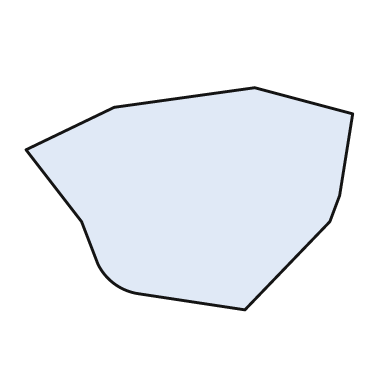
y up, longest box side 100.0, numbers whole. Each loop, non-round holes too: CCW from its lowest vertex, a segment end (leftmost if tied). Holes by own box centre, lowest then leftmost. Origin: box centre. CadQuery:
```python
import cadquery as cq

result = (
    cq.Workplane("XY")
    .moveTo(17.0, -34.0)
    .lineTo(43.0, -7.0)
    .lineTo(46.0, 1.0)
    .lineTo(50.0, 26.0)
    .lineTo(20.0, 34.0)
    .lineTo(-23.0, 28.0)
    .lineTo(-50.0, 15.0)
    .lineTo(-33.0, -7.0)
    .lineTo(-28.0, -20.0)
    .threePointArc((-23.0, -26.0), (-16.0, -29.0))
    .close()
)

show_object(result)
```